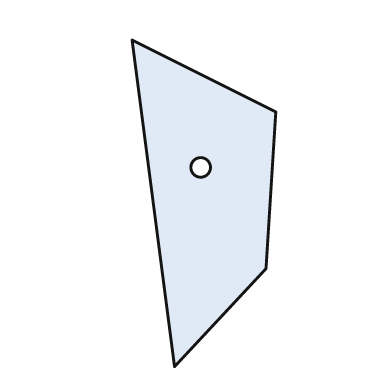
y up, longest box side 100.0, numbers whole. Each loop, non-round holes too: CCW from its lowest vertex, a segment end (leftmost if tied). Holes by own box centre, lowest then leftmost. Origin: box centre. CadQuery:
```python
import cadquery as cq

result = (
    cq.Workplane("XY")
    .moveTo(-9.0, -50.0)
    .lineTo(19.0, -20.0)
    .lineTo(22.0, 28.0)
    .lineTo(-22.0, 50.0)
    .close()
    .moveTo(-1.0, 11.0)
    .circle(3.0)
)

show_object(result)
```